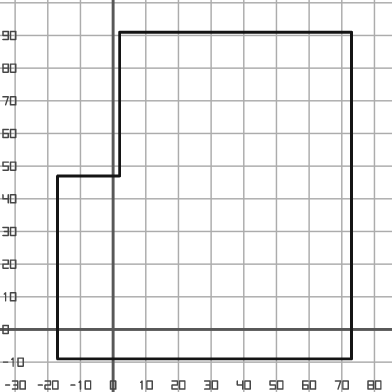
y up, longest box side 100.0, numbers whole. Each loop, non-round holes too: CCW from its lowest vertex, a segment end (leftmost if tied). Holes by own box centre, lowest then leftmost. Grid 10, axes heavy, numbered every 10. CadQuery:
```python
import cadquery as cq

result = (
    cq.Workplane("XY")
    .moveTo(-17.0, -9.0)
    .lineTo(73.0, -9.0)
    .lineTo(73.0, 91.0)
    .lineTo(2.0, 91.0)
    .lineTo(2.0, 47.0)
    .lineTo(-17.0, 47.0)
    .close()
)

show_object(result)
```